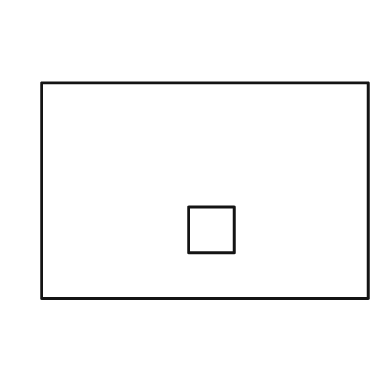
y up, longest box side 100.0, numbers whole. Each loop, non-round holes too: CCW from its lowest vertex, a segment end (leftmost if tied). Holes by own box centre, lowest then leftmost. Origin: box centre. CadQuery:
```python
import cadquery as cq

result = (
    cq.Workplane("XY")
    .moveTo(-50.0, -33.0)
    .lineTo(50.0, -33.0)
    .lineTo(50.0, 33.0)
    .lineTo(-50.0, 33.0)
    .close()
    .moveTo(-5.0, -19.0)
    .lineTo(9.0, -19.0)
    .lineTo(9.0, -5.0)
    .lineTo(-5.0, -5.0)
    .close()
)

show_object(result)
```